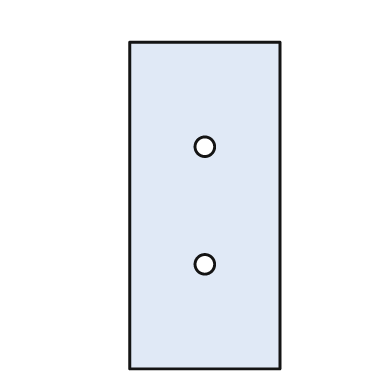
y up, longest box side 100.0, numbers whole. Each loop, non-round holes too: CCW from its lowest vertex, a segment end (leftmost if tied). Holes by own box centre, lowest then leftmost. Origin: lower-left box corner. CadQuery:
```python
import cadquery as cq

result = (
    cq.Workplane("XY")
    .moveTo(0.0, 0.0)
    .lineTo(46.0, 0.0)
    .lineTo(46.0, 100.0)
    .lineTo(0.0, 100.0)
    .close()
    .moveTo(23.0, 32.0)
    .circle(3.0)
    .moveTo(23.0, 68.0)
    .circle(3.0)
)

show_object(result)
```